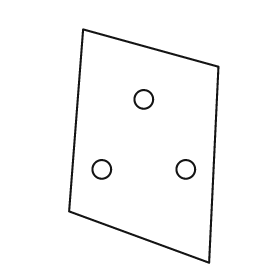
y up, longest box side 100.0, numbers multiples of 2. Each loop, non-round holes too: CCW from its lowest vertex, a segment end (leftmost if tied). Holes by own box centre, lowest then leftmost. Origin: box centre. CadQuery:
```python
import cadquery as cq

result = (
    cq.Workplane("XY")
    .moveTo(28.0, -50.0)
    .lineTo(32.0, 34.0)
    .lineTo(-26.0, 50.0)
    .lineTo(-32.0, -28.0)
    .close()
    .moveTo(-18.0, -10.0)
    .circle(4.0)
    .moveTo(18.0, -10.0)
    .circle(4.0)
    .moveTo(0.0, 20.0)
    .circle(4.0)
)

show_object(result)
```